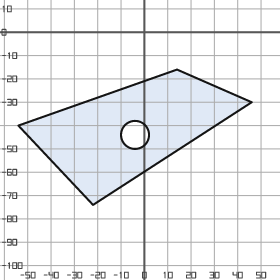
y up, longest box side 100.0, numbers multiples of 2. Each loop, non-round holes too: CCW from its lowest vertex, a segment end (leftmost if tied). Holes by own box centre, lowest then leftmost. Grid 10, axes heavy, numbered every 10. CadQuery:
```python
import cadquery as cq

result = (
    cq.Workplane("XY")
    .moveTo(-22.0, -74.0)
    .lineTo(46.0, -30.0)
    .lineTo(14.0, -16.0)
    .lineTo(-54.0, -40.0)
    .close()
    .moveTo(-4.0, -44.0)
    .circle(6.0)
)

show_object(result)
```